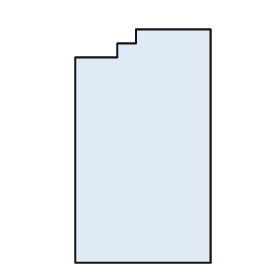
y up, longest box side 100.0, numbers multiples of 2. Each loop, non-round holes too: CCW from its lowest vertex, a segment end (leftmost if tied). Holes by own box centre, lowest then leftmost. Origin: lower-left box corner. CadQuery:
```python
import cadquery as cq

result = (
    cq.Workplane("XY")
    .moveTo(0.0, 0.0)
    .lineTo(58.0, 0.0)
    .lineTo(58.0, 100.0)
    .lineTo(26.0, 100.0)
    .lineTo(26.0, 94.0)
    .lineTo(18.0, 94.0)
    .lineTo(18.0, 88.0)
    .lineTo(0.0, 88.0)
    .close()
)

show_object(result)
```